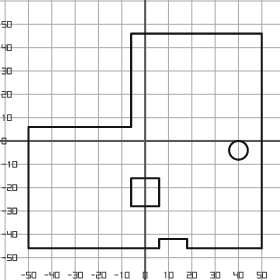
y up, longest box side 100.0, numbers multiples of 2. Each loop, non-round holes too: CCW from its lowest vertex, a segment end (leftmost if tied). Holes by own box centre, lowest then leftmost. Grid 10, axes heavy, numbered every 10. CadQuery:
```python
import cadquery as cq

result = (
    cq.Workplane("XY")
    .moveTo(-50.0, -46.0)
    .lineTo(6.0, -46.0)
    .lineTo(6.0, -42.0)
    .lineTo(18.0, -42.0)
    .lineTo(18.0, -46.0)
    .lineTo(50.0, -46.0)
    .lineTo(50.0, 46.0)
    .lineTo(-6.0, 46.0)
    .lineTo(-6.0, 6.0)
    .lineTo(-50.0, 6.0)
    .close()
    .moveTo(-6.0, -28.0)
    .lineTo(6.0, -28.0)
    .lineTo(6.0, -16.0)
    .lineTo(-6.0, -16.0)
    .close()
    .moveTo(40.0, -4.0)
    .circle(4.0)
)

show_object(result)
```